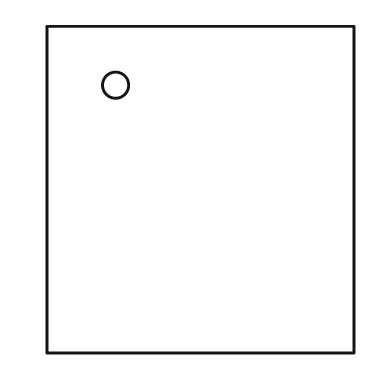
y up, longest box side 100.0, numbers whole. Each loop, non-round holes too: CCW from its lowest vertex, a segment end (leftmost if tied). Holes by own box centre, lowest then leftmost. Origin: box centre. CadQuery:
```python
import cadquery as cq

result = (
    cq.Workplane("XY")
    .moveTo(-47.0, -50.0)
    .lineTo(47.0, -50.0)
    .lineTo(47.0, 50.0)
    .lineTo(-47.0, 50.0)
    .close()
    .moveTo(-26.0, 32.0)
    .circle(4.0)
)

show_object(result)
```